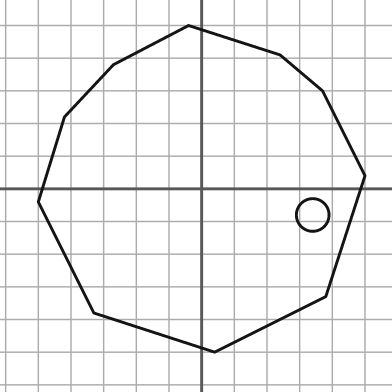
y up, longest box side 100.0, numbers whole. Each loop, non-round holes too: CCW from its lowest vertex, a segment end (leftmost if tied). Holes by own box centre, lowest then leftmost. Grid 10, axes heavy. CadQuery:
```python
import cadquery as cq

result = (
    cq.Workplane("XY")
    .moveTo(4.0, -50.0)
    .lineTo(38.0, -33.0)
    .lineTo(50.0, 4.0)
    .lineTo(37.0, 30.0)
    .lineTo(24.0, 41.0)
    .lineTo(-4.0, 50.0)
    .lineTo(-27.0, 38.0)
    .lineTo(-42.0, 22.0)
    .lineTo(-50.0, -4.0)
    .lineTo(-33.0, -38.0)
    .close()
    .moveTo(34.0, -8.0)
    .circle(5.0)
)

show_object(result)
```